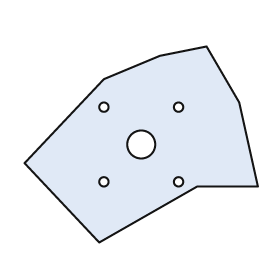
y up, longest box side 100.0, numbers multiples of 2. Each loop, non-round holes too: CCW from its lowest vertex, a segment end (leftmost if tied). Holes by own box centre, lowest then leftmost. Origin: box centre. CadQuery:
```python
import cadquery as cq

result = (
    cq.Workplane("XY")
    .moveTo(-18.0, -42.0)
    .lineTo(24.0, -18.0)
    .lineTo(50.0, -18.0)
    .lineTo(42.0, 18.0)
    .lineTo(28.0, 42.0)
    .lineTo(8.0, 38.0)
    .lineTo(-16.0, 28.0)
    .lineTo(-50.0, -8.0)
    .close()
    .moveTo(-16.0, -16.0)
    .circle(2.0)
    .moveTo(16.0, -16.0)
    .circle(2.0)
    .moveTo(0.0, 0.0)
    .circle(6.0)
    .moveTo(-16.0, 16.0)
    .circle(2.0)
    .moveTo(16.0, 16.0)
    .circle(2.0)
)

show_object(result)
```